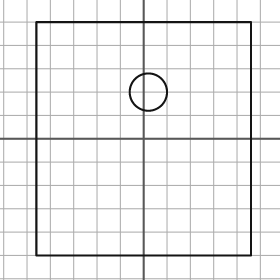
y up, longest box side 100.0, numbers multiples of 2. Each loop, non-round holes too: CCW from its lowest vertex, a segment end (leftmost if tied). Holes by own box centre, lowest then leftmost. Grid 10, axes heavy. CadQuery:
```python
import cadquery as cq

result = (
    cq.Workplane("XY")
    .moveTo(-46.0, -50.0)
    .lineTo(46.0, -50.0)
    .lineTo(46.0, 50.0)
    .lineTo(-46.0, 50.0)
    .close()
    .moveTo(2.0, 20.0)
    .circle(8.0)
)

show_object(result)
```